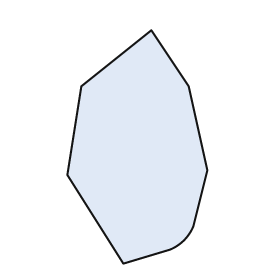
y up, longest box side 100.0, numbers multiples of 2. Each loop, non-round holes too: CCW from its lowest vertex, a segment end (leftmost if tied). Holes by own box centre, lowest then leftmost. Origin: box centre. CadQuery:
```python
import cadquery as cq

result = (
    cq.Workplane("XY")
    .moveTo(-6.0, -50.0)
    .lineTo(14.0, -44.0)
    .threePointArc((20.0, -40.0), (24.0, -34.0))
    .lineTo(30.0, -10.0)
    .lineTo(22.0, 26.0)
    .lineTo(6.0, 50.0)
    .lineTo(-24.0, 26.0)
    .lineTo(-30.0, -12.0)
    .close()
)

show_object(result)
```